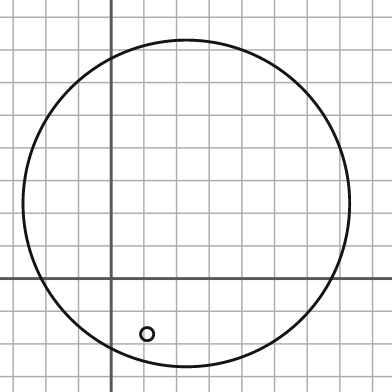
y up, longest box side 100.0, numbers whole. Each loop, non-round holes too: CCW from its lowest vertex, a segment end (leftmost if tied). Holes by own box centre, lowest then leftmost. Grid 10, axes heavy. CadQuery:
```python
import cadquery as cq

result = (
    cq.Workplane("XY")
    .moveTo(23.0, 23.0)
    .circle(50.0)
    .moveTo(11.0, -17.0)
    .circle(2.0)
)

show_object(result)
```